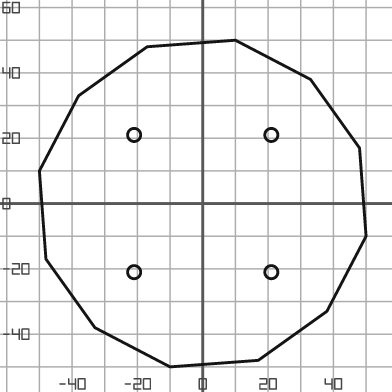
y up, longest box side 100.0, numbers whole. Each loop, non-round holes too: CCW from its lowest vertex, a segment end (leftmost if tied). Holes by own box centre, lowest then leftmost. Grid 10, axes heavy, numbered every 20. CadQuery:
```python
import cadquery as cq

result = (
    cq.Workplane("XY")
    .moveTo(-10.0, -50.0)
    .lineTo(17.0, -48.0)
    .lineTo(38.0, -33.0)
    .lineTo(50.0, -10.0)
    .lineTo(48.0, 17.0)
    .lineTo(33.0, 38.0)
    .lineTo(10.0, 50.0)
    .lineTo(-17.0, 48.0)
    .lineTo(-38.0, 33.0)
    .lineTo(-50.0, 10.0)
    .lineTo(-48.0, -17.0)
    .lineTo(-33.0, -38.0)
    .close()
    .moveTo(-21.0, -21.0)
    .circle(2.0)
    .moveTo(21.0, -21.0)
    .circle(2.0)
    .moveTo(-21.0, 21.0)
    .circle(2.0)
    .moveTo(21.0, 21.0)
    .circle(2.0)
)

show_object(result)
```